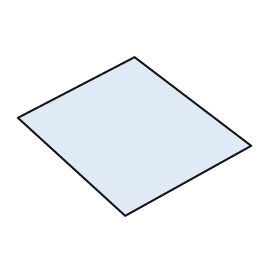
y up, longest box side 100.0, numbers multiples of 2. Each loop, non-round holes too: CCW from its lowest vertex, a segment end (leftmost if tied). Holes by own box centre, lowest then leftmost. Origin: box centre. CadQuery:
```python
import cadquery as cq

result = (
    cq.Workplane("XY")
    .moveTo(-4.0, -34.0)
    .lineTo(50.0, -4.0)
    .lineTo(0.0, 34.0)
    .lineTo(-50.0, 8.0)
    .close()
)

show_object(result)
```